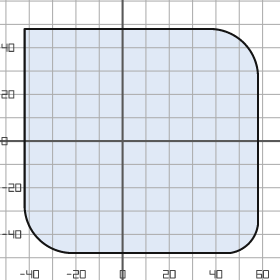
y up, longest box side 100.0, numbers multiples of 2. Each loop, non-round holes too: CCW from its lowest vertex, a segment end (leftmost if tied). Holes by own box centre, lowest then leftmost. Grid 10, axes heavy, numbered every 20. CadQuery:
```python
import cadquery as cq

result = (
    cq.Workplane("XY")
    .moveTo(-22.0, -48.0)
    .lineTo(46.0, -48.0)
    .threePointArc((54.0, -44.0), (58.0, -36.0))
    .lineTo(58.0, 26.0)
    .threePointArc((52.0, 42.0), (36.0, 48.0))
    .lineTo(-42.0, 48.0)
    .lineTo(-42.0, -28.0)
    .threePointArc((-36.0, -42.0), (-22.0, -48.0))
    .close()
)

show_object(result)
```